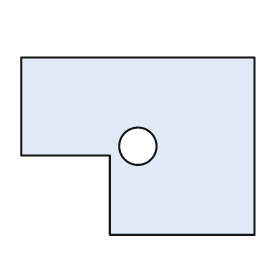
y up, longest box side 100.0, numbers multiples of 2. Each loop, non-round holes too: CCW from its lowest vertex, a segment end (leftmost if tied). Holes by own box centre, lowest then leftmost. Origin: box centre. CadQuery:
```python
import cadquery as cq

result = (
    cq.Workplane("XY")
    .moveTo(-12.0, -38.0)
    .lineTo(50.0, -38.0)
    .lineTo(50.0, 38.0)
    .lineTo(-50.0, 38.0)
    .lineTo(-50.0, -4.0)
    .lineTo(-12.0, -4.0)
    .close()
    .moveTo(0.0, 0.0)
    .circle(8.0)
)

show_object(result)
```